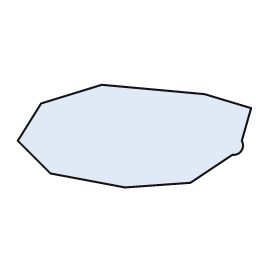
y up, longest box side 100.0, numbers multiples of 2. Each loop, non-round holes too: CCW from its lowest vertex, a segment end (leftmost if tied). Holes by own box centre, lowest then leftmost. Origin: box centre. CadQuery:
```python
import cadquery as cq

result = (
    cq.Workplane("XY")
    .moveTo(-4.0, -22.0)
    .lineTo(24.0, -20.0)
    .lineTo(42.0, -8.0)
    .threePointArc((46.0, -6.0), (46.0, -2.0))
    .lineTo(50.0, 12.0)
    .lineTo(30.0, 18.0)
    .lineTo(-14.0, 22.0)
    .lineTo(-40.0, 14.0)
    .lineTo(-50.0, -2.0)
    .lineTo(-36.0, -16.0)
    .close()
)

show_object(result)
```